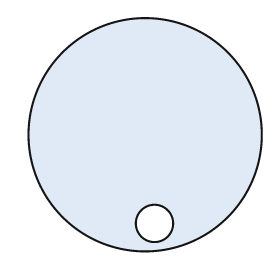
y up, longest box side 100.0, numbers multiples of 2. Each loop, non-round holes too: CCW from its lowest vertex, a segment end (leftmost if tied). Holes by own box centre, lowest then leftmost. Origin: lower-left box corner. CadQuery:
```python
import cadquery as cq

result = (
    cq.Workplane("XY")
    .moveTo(50.0, 50.0)
    .circle(50.0)
    .moveTo(54.0, 12.0)
    .circle(8.0)
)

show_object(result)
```